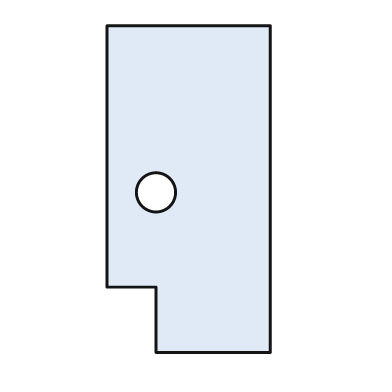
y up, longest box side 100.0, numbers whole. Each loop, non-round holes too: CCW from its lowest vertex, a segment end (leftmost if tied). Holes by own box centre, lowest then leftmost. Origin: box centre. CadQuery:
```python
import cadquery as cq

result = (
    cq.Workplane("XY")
    .moveTo(-10.0, -50.0)
    .lineTo(25.0, -50.0)
    .lineTo(25.0, 50.0)
    .lineTo(-25.0, 50.0)
    .lineTo(-25.0, -30.0)
    .lineTo(-10.0, -30.0)
    .close()
    .moveTo(-10.0, -1.0)
    .circle(6.0)
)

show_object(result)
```